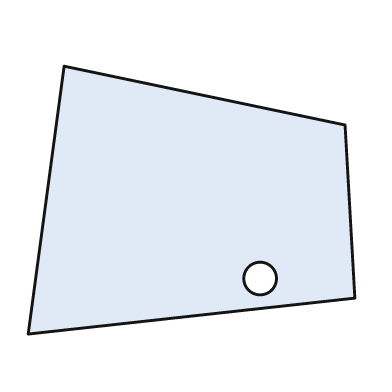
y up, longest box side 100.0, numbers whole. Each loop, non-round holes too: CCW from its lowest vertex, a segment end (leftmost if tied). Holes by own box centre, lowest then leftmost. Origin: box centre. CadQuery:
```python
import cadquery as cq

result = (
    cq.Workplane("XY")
    .moveTo(-50.0, -41.0)
    .lineTo(50.0, -30.0)
    .lineTo(47.0, 23.0)
    .lineTo(-39.0, 41.0)
    .close()
    .moveTo(21.0, -24.0)
    .circle(5.0)
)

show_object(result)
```